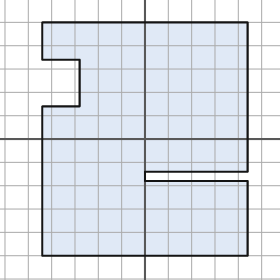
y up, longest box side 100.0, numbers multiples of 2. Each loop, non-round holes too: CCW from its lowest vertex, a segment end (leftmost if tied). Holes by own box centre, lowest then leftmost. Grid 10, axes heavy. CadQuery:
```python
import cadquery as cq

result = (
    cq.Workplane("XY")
    .moveTo(-44.0, -50.0)
    .lineTo(44.0, -50.0)
    .lineTo(44.0, -18.0)
    .lineTo(0.0, -18.0)
    .lineTo(0.0, -14.0)
    .lineTo(44.0, -14.0)
    .lineTo(44.0, 50.0)
    .lineTo(-44.0, 50.0)
    .lineTo(-44.0, 34.0)
    .lineTo(-28.0, 34.0)
    .lineTo(-28.0, 14.0)
    .lineTo(-44.0, 14.0)
    .close()
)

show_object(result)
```